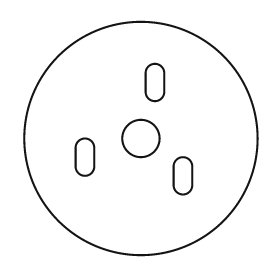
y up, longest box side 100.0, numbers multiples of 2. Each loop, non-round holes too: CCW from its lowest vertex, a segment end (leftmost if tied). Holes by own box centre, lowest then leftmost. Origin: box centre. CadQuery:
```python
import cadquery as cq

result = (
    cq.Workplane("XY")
    .moveTo(0.0, 0.0)
    .circle(50.0)
    .moveTo(14.0, -20.0)
    .threePointArc((18.0, -24.0), (22.0, -20.0))
    .lineTo(22.0, -12.0)
    .threePointArc((18.0, -8.0), (14.0, -12.0))
    .close()
    .moveTo(-28.0, -12.0)
    .threePointArc((-24.0, -16.0), (-20.0, -12.0))
    .lineTo(-20.0, -4.0)
    .threePointArc((-24.0, 0.0), (-28.0, -4.0))
    .close()
    .moveTo(0.0, 0.0)
    .circle(8.0)
    .moveTo(2.0, 20.0)
    .threePointArc((6.0, 16.0), (10.0, 20.0))
    .lineTo(10.0, 28.0)
    .threePointArc((6.0, 32.0), (2.0, 28.0))
    .close()
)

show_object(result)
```